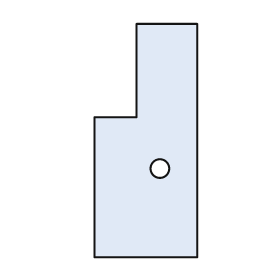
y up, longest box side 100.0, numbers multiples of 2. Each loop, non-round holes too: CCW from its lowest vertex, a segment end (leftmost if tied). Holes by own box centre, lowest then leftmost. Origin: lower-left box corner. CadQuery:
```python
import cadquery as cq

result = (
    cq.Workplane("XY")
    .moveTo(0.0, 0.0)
    .lineTo(44.0, 0.0)
    .lineTo(44.0, 100.0)
    .lineTo(18.0, 100.0)
    .lineTo(18.0, 60.0)
    .lineTo(0.0, 60.0)
    .close()
    .moveTo(28.0, 38.0)
    .circle(4.0)
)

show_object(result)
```